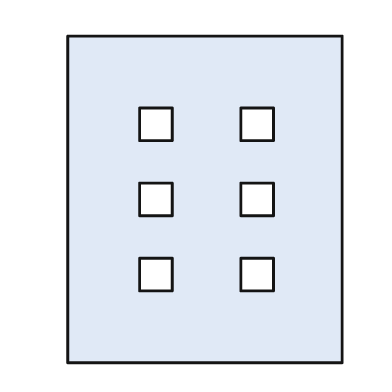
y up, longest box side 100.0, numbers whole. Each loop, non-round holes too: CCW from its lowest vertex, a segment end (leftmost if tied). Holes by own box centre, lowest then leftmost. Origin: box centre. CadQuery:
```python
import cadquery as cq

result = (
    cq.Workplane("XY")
    .moveTo(-42.0, -50.0)
    .lineTo(42.0, -50.0)
    .lineTo(42.0, 50.0)
    .lineTo(-42.0, 50.0)
    .close()
    .moveTo(-20.0, -28.0)
    .lineTo(-10.0, -28.0)
    .lineTo(-10.0, -18.0)
    .lineTo(-20.0, -18.0)
    .close()
    .moveTo(11.0, -28.0)
    .lineTo(21.0, -28.0)
    .lineTo(21.0, -18.0)
    .lineTo(11.0, -18.0)
    .close()
    .moveTo(-20.0, -5.0)
    .lineTo(-10.0, -5.0)
    .lineTo(-10.0, 5.0)
    .lineTo(-20.0, 5.0)
    .close()
    .moveTo(11.0, -5.0)
    .lineTo(21.0, -5.0)
    .lineTo(21.0, 5.0)
    .lineTo(11.0, 5.0)
    .close()
    .moveTo(-20.0, 18.0)
    .lineTo(-10.0, 18.0)
    .lineTo(-10.0, 28.0)
    .lineTo(-20.0, 28.0)
    .close()
    .moveTo(11.0, 18.0)
    .lineTo(21.0, 18.0)
    .lineTo(21.0, 28.0)
    .lineTo(11.0, 28.0)
    .close()
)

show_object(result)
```